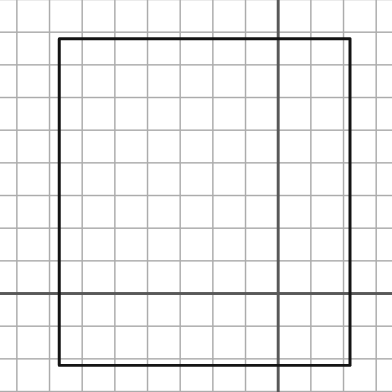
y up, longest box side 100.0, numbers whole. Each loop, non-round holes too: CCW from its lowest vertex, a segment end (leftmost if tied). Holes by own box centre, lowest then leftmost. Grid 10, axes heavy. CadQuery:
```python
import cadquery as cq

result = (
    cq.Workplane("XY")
    .moveTo(-67.0, -22.0)
    .lineTo(22.0, -22.0)
    .lineTo(22.0, 78.0)
    .lineTo(-67.0, 78.0)
    .close()
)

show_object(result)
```